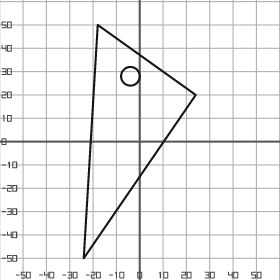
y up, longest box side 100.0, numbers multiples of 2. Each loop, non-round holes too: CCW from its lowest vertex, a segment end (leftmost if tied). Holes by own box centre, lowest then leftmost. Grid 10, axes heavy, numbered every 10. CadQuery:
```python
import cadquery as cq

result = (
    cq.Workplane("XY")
    .moveTo(-24.0, -50.0)
    .lineTo(24.0, 20.0)
    .lineTo(-18.0, 50.0)
    .close()
    .moveTo(-4.0, 28.0)
    .circle(4.0)
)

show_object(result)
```